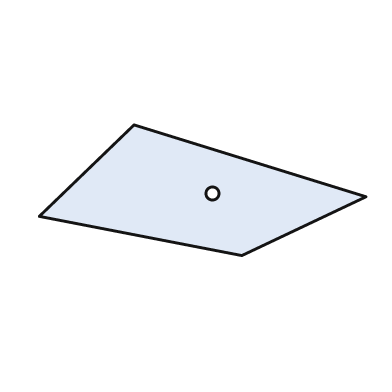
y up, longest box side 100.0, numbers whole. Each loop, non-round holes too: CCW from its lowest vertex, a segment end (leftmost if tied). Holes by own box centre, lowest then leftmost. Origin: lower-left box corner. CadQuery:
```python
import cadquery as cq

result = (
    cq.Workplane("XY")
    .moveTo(62.0, 0.0)
    .lineTo(100.0, 18.0)
    .lineTo(29.0, 40.0)
    .lineTo(0.0, 12.0)
    .close()
    .moveTo(53.0, 19.0)
    .circle(2.0)
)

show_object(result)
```